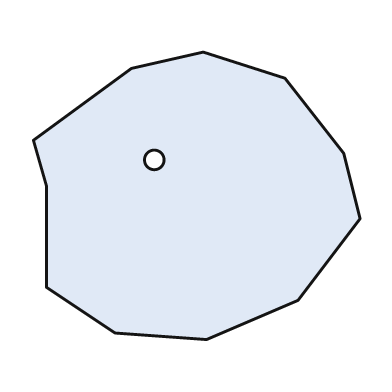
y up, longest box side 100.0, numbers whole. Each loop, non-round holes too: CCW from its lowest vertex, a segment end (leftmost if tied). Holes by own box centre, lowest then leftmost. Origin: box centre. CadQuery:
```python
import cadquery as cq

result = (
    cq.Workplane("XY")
    .moveTo(3.0, -44.0)
    .lineTo(31.0, -32.0)
    .lineTo(50.0, -7.0)
    .lineTo(45.0, 13.0)
    .lineTo(27.0, 36.0)
    .lineTo(2.0, 44.0)
    .lineTo(-20.0, 39.0)
    .lineTo(-50.0, 17.0)
    .lineTo(-46.0, 3.0)
    .lineTo(-46.0, -28.0)
    .lineTo(-25.0, -42.0)
    .close()
    .moveTo(-13.0, 11.0)
    .circle(3.0)
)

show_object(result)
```